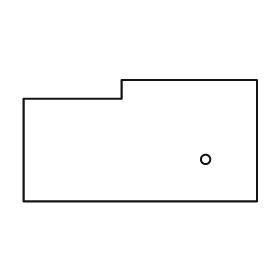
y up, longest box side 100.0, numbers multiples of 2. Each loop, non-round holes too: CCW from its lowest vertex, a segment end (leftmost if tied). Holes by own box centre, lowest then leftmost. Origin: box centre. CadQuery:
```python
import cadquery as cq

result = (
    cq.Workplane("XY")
    .moveTo(-50.0, -26.0)
    .lineTo(50.0, -26.0)
    .lineTo(50.0, 26.0)
    .lineTo(-8.0, 26.0)
    .lineTo(-8.0, 18.0)
    .lineTo(-50.0, 18.0)
    .close()
    .moveTo(28.0, -8.0)
    .circle(2.0)
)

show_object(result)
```